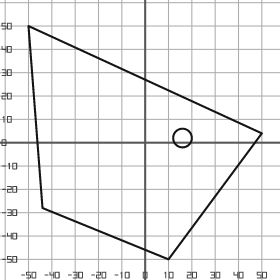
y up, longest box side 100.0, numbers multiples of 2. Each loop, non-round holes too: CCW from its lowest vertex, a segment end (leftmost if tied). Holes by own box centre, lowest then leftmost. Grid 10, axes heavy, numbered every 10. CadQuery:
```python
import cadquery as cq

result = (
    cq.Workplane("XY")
    .moveTo(10.0, -50.0)
    .lineTo(50.0, 4.0)
    .lineTo(-50.0, 50.0)
    .lineTo(-44.0, -28.0)
    .close()
    .moveTo(16.0, 2.0)
    .circle(4.0)
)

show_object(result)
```